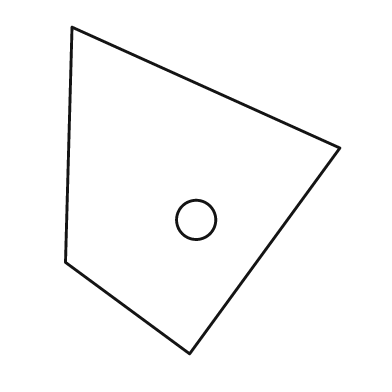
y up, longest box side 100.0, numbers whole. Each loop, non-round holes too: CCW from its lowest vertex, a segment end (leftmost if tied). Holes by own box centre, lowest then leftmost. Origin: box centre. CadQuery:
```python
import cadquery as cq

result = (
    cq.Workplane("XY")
    .moveTo(-4.0, -50.0)
    .lineTo(42.0, 13.0)
    .lineTo(-40.0, 50.0)
    .lineTo(-42.0, -22.0)
    .close()
    .moveTo(-2.0, -9.0)
    .circle(6.0)
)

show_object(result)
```